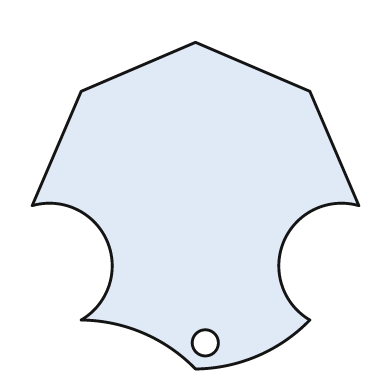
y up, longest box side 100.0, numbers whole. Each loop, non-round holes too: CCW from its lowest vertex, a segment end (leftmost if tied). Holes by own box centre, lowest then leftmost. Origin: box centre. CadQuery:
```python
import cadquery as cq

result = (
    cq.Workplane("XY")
    .moveTo(0.0, -50.0)
    .threePointArc((19.0, -46.0), (35.0, -35.0))
    .threePointArc((27.0, -11.0), (50.0, 0.0))
    .lineTo(35.0, 35.0)
    .lineTo(0.0, 50.0)
    .lineTo(-35.0, 35.0)
    .lineTo(-50.0, 0.0)
    .threePointArc((-27.0, -11.0), (-35.0, -35.0))
    .threePointArc((-16.0, -39.0), (0.0, -50.0))
    .close()
    .moveTo(3.0, -42.0)
    .circle(4.0)
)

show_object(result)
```